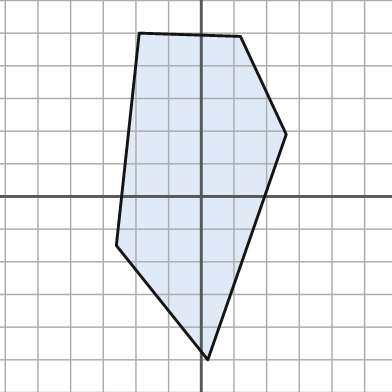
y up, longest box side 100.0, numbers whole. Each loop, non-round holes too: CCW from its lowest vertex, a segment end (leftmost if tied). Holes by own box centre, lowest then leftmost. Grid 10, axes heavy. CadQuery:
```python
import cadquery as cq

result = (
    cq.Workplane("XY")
    .moveTo(2.0, -50.0)
    .lineTo(26.0, 19.0)
    .lineTo(12.0, 49.0)
    .lineTo(-19.0, 50.0)
    .lineTo(-26.0, -15.0)
    .close()
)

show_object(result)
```